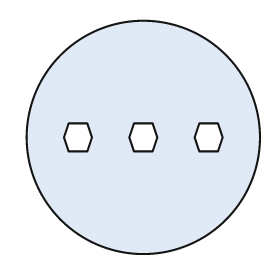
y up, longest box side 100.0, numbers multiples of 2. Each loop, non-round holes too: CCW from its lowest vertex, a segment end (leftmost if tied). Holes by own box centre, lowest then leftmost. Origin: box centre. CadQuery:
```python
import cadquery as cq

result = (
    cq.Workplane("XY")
    .moveTo(0.0, 0.0)
    .circle(50.0)
    .moveTo(-32.0, -6.0)
    .lineTo(-24.0, -6.0)
    .lineTo(-22.0, 0.0)
    .lineTo(-24.0, 6.0)
    .lineTo(-32.0, 6.0)
    .lineTo(-34.0, 0.0)
    .close()
    .moveTo(-4.0, -6.0)
    .lineTo(4.0, -6.0)
    .lineTo(6.0, 0.0)
    .lineTo(4.0, 6.0)
    .lineTo(-4.0, 6.0)
    .lineTo(-6.0, 0.0)
    .close()
    .moveTo(24.0, -6.0)
    .lineTo(32.0, -6.0)
    .lineTo(34.0, 0.0)
    .lineTo(32.0, 6.0)
    .lineTo(24.0, 6.0)
    .lineTo(22.0, 0.0)
    .close()
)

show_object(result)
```